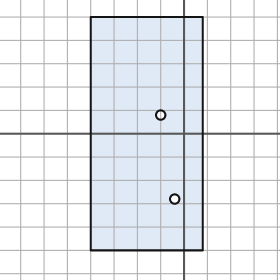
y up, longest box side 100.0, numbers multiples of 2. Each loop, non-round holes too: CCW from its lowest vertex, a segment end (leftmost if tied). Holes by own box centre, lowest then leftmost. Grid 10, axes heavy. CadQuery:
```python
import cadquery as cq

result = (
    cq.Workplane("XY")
    .moveTo(-40.0, -50.0)
    .lineTo(8.0, -50.0)
    .lineTo(8.0, 50.0)
    .lineTo(-40.0, 50.0)
    .close()
    .moveTo(-4.0, -28.0)
    .circle(2.0)
    .moveTo(-10.0, 8.0)
    .circle(2.0)
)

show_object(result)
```